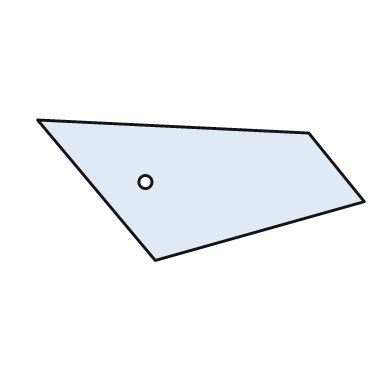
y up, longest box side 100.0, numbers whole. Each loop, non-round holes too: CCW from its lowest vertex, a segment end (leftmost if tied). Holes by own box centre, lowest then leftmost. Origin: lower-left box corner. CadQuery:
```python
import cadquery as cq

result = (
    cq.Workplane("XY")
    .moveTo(36.0, 0.0)
    .lineTo(100.0, 18.0)
    .lineTo(83.0, 39.0)
    .lineTo(0.0, 43.0)
    .close()
    .moveTo(33.0, 24.0)
    .circle(2.0)
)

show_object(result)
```